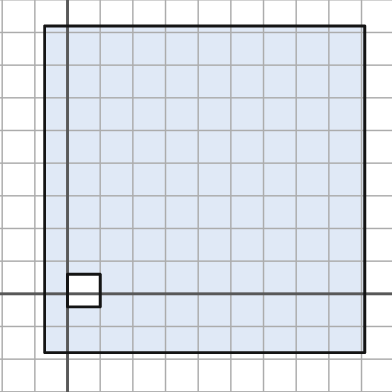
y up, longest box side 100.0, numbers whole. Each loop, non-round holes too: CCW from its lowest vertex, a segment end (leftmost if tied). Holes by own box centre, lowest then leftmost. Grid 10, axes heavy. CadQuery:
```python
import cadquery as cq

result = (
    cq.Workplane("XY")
    .moveTo(-7.0, -18.0)
    .lineTo(91.0, -18.0)
    .lineTo(91.0, 82.0)
    .lineTo(-7.0, 82.0)
    .close()
    .moveTo(0.0, -4.0)
    .lineTo(10.0, -4.0)
    .lineTo(10.0, 6.0)
    .lineTo(0.0, 6.0)
    .close()
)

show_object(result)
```